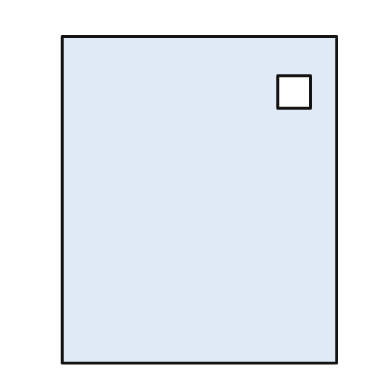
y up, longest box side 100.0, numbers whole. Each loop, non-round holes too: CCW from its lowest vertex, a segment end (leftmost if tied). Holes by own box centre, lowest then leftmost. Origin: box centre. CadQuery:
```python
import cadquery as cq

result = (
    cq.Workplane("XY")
    .moveTo(-42.0, -50.0)
    .lineTo(42.0, -50.0)
    .lineTo(42.0, 50.0)
    .lineTo(-42.0, 50.0)
    .close()
    .moveTo(24.0, 28.0)
    .lineTo(34.0, 28.0)
    .lineTo(34.0, 38.0)
    .lineTo(24.0, 38.0)
    .close()
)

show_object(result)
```